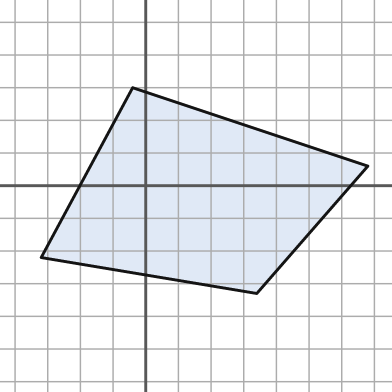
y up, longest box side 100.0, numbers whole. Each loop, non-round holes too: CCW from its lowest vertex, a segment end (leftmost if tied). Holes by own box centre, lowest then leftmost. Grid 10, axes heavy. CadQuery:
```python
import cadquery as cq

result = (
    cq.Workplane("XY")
    .moveTo(34.0, -33.0)
    .lineTo(68.0, 6.0)
    .lineTo(-4.0, 30.0)
    .lineTo(-32.0, -22.0)
    .close()
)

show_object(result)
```